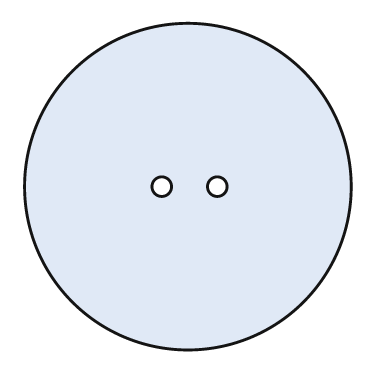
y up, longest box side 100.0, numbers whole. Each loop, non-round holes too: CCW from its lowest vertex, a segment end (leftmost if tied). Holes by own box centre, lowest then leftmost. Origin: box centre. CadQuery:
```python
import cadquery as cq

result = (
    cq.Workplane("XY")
    .moveTo(0.0, 0.0)
    .circle(50.0)
    .moveTo(-8.0, 0.0)
    .circle(3.0)
    .moveTo(9.0, 0.0)
    .circle(3.0)
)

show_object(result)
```